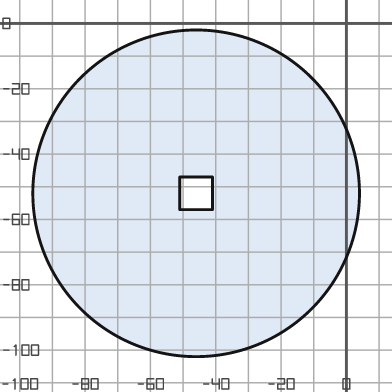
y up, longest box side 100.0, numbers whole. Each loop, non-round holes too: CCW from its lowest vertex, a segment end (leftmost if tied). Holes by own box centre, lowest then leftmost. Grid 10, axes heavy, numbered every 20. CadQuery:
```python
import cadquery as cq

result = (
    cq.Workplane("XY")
    .moveTo(-46.0, -52.0)
    .circle(50.0)
    .moveTo(-51.0, -57.0)
    .lineTo(-41.0, -57.0)
    .lineTo(-41.0, -47.0)
    .lineTo(-51.0, -47.0)
    .close()
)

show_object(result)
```